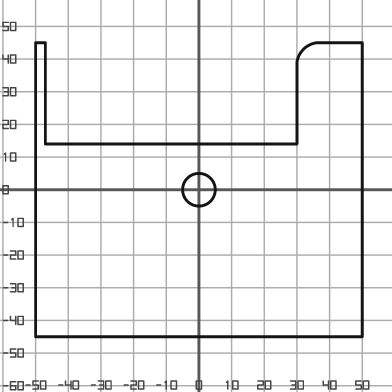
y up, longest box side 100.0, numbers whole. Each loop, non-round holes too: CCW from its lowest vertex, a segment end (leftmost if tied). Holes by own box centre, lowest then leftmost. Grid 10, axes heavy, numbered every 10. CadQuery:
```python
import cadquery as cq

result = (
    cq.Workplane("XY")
    .moveTo(-50.0, -45.0)
    .lineTo(50.0, -45.0)
    .lineTo(50.0, 45.0)
    .lineTo(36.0, 45.0)
    .threePointArc((32.0, 43.0), (30.0, 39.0))
    .lineTo(30.0, 14.0)
    .lineTo(-47.0, 14.0)
    .lineTo(-47.0, 45.0)
    .lineTo(-50.0, 45.0)
    .close()
    .moveTo(0.0, 0.0)
    .circle(5.0)
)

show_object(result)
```